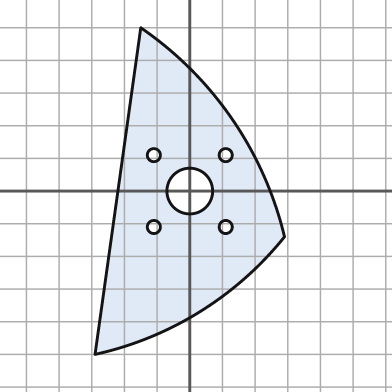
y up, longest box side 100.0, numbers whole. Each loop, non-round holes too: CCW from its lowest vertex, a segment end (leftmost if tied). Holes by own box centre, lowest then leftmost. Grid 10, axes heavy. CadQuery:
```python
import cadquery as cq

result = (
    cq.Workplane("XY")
    .moveTo(-29.0, -50.0)
    .threePointArc((3.0, -37.0), (29.0, -14.0))
    .threePointArc((13.0, 22.0), (-15.0, 50.0))
    .close()
    .moveTo(-11.0, -11.0)
    .circle(2.0)
    .moveTo(11.0, -11.0)
    .circle(2.0)
    .moveTo(0.0, 0.0)
    .circle(7.0)
    .moveTo(-11.0, 11.0)
    .circle(2.0)
    .moveTo(11.0, 11.0)
    .circle(2.0)
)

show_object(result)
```